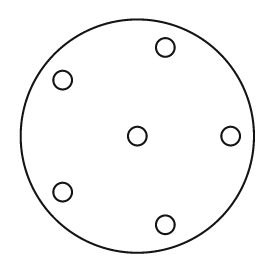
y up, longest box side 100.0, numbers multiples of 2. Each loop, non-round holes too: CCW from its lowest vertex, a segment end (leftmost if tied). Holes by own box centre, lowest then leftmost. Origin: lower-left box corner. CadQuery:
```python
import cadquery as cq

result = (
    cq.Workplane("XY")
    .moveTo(50.0, 50.0)
    .circle(50.0)
    .moveTo(62.0, 12.0)
    .circle(4.0)
    .moveTo(18.0, 26.0)
    .circle(4.0)
    .moveTo(50.0, 50.0)
    .circle(4.0)
    .moveTo(90.0, 50.0)
    .circle(4.0)
    .moveTo(18.0, 74.0)
    .circle(4.0)
    .moveTo(62.0, 88.0)
    .circle(4.0)
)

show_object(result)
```